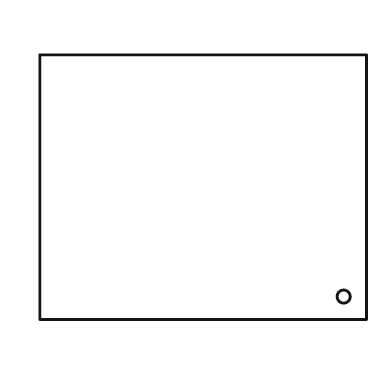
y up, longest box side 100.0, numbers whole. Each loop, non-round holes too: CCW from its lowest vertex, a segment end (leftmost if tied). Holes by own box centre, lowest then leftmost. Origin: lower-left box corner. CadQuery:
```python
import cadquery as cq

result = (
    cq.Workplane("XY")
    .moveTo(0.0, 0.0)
    .lineTo(100.0, 0.0)
    .lineTo(100.0, 81.0)
    .lineTo(0.0, 81.0)
    .close()
    .moveTo(93.0, 7.0)
    .circle(2.0)
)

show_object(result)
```